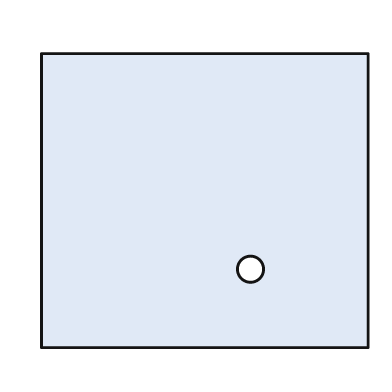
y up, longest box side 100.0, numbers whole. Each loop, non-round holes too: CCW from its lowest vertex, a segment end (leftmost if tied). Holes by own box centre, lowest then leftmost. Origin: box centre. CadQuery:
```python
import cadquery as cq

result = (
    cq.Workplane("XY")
    .moveTo(-50.0, -45.0)
    .lineTo(50.0, -45.0)
    .lineTo(50.0, 45.0)
    .lineTo(-50.0, 45.0)
    .close()
    .moveTo(14.0, -21.0)
    .circle(4.0)
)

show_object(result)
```